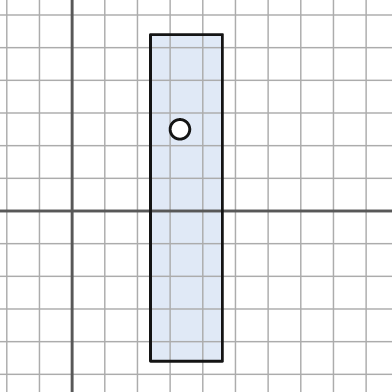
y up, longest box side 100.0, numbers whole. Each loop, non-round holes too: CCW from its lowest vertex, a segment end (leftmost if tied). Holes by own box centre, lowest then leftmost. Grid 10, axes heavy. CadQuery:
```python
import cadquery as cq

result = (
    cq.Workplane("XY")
    .moveTo(24.0, -46.0)
    .lineTo(46.0, -46.0)
    .lineTo(46.0, 54.0)
    .lineTo(24.0, 54.0)
    .close()
    .moveTo(33.0, 25.0)
    .circle(3.0)
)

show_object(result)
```